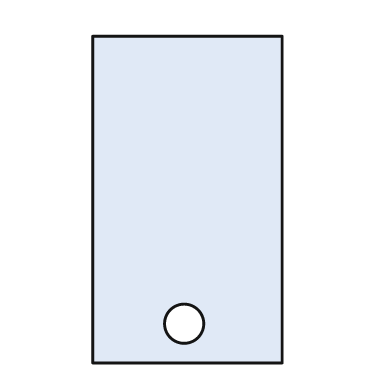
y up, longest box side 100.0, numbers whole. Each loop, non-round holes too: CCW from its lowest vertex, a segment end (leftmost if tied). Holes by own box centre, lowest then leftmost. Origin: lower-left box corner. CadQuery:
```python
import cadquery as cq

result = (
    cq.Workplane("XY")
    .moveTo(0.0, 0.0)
    .lineTo(58.0, 0.0)
    .lineTo(58.0, 100.0)
    .lineTo(0.0, 100.0)
    .close()
    .moveTo(28.0, 12.0)
    .circle(6.0)
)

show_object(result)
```